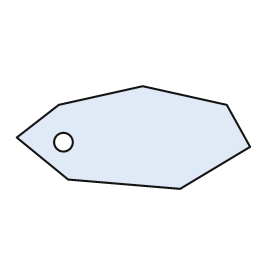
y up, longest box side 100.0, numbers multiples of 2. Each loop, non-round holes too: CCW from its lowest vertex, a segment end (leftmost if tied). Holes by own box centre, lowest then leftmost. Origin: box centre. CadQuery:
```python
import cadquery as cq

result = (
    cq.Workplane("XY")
    .moveTo(20.0, -22.0)
    .lineTo(50.0, -4.0)
    .lineTo(40.0, 14.0)
    .lineTo(4.0, 22.0)
    .lineTo(-32.0, 14.0)
    .lineTo(-50.0, 0.0)
    .lineTo(-28.0, -18.0)
    .close()
    .moveTo(-30.0, -2.0)
    .circle(4.0)
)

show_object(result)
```